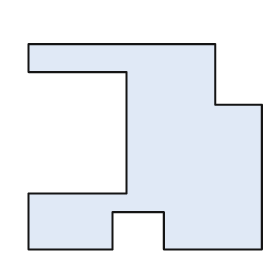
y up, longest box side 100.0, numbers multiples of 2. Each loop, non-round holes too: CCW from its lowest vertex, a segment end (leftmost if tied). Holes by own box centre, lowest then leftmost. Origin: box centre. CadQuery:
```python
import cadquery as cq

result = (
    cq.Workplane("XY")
    .moveTo(-50.0, -44.0)
    .lineTo(-14.0, -44.0)
    .lineTo(-14.0, -28.0)
    .lineTo(8.0, -28.0)
    .lineTo(8.0, -44.0)
    .lineTo(50.0, -44.0)
    .lineTo(50.0, 18.0)
    .lineTo(30.0, 18.0)
    .lineTo(30.0, 44.0)
    .lineTo(-50.0, 44.0)
    .lineTo(-50.0, 32.0)
    .lineTo(-8.0, 32.0)
    .lineTo(-8.0, -20.0)
    .lineTo(-50.0, -20.0)
    .close()
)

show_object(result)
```